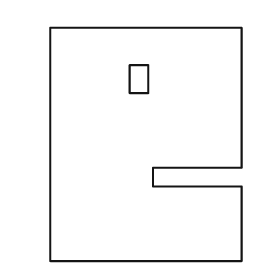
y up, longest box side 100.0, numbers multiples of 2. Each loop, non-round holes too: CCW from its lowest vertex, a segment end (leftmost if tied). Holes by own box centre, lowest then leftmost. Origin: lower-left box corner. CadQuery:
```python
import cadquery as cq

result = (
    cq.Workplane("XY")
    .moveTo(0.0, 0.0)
    .lineTo(82.0, 0.0)
    .lineTo(82.0, 32.0)
    .lineTo(44.0, 32.0)
    .lineTo(44.0, 40.0)
    .lineTo(82.0, 40.0)
    .lineTo(82.0, 100.0)
    .lineTo(0.0, 100.0)
    .close()
    .moveTo(34.0, 72.0)
    .lineTo(42.0, 72.0)
    .lineTo(42.0, 84.0)
    .lineTo(34.0, 84.0)
    .close()
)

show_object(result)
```